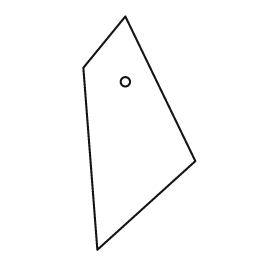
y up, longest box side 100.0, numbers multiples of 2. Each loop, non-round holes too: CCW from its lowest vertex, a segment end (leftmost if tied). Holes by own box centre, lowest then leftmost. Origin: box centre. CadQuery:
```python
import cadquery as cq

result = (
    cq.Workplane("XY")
    .moveTo(-18.0, -50.0)
    .lineTo(24.0, -12.0)
    .lineTo(-6.0, 50.0)
    .lineTo(-24.0, 28.0)
    .close()
    .moveTo(-6.0, 22.0)
    .circle(2.0)
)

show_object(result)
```